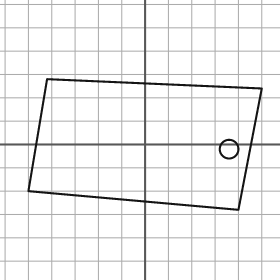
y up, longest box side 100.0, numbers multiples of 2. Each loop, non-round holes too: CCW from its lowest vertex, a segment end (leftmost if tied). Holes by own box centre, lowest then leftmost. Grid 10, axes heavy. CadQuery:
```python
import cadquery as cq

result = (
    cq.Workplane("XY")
    .moveTo(40.0, -28.0)
    .lineTo(50.0, 24.0)
    .lineTo(-42.0, 28.0)
    .lineTo(-50.0, -20.0)
    .close()
    .moveTo(36.0, -2.0)
    .circle(4.0)
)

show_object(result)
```